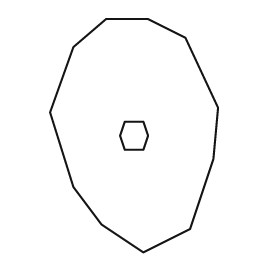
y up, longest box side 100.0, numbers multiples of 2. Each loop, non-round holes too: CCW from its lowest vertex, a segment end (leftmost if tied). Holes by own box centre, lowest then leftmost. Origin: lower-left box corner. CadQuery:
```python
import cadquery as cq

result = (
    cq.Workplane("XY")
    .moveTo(40.0, 0.0)
    .lineTo(60.0, 10.0)
    .lineTo(70.0, 40.0)
    .lineTo(72.0, 62.0)
    .lineTo(58.0, 92.0)
    .lineTo(42.0, 100.0)
    .lineTo(24.0, 100.0)
    .lineTo(10.0, 88.0)
    .lineTo(0.0, 60.0)
    .lineTo(10.0, 28.0)
    .lineTo(22.0, 12.0)
    .close()
    .moveTo(32.0, 44.0)
    .lineTo(40.0, 44.0)
    .lineTo(42.0, 50.0)
    .lineTo(40.0, 56.0)
    .lineTo(32.0, 56.0)
    .lineTo(30.0, 50.0)
    .close()
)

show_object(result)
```